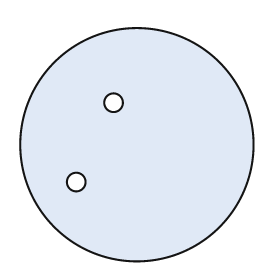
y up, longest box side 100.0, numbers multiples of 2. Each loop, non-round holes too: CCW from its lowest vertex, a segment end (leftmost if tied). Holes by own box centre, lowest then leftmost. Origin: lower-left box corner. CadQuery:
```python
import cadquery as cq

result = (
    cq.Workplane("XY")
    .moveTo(50.0, 50.0)
    .circle(50.0)
    .moveTo(24.0, 34.0)
    .circle(4.0)
    .moveTo(40.0, 68.0)
    .circle(4.0)
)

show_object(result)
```